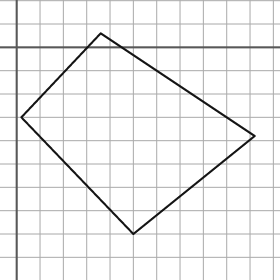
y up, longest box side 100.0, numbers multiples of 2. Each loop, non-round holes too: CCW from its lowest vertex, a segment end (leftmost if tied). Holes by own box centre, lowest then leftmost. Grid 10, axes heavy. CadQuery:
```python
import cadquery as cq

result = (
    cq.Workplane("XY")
    .moveTo(50.0, -80.0)
    .lineTo(102.0, -38.0)
    .lineTo(36.0, 6.0)
    .lineTo(2.0, -30.0)
    .close()
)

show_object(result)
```